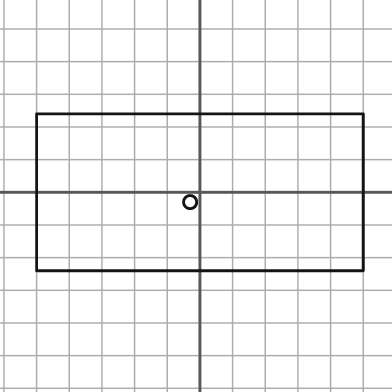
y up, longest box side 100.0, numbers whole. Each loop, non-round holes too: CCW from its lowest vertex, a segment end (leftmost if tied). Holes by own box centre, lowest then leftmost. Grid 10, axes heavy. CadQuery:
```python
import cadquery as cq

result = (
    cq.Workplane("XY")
    .moveTo(-50.0, -24.0)
    .lineTo(50.0, -24.0)
    .lineTo(50.0, 24.0)
    .lineTo(-50.0, 24.0)
    .close()
    .moveTo(-3.0, -3.0)
    .circle(2.0)
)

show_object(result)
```